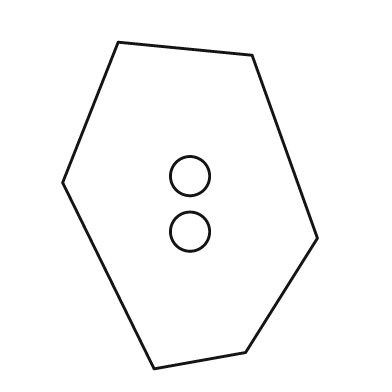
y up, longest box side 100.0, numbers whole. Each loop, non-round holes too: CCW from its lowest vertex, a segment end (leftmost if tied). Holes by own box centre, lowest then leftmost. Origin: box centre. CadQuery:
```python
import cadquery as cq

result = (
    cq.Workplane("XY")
    .moveTo(-11.0, -50.0)
    .lineTo(17.0, -45.0)
    .lineTo(39.0, -10.0)
    .lineTo(19.0, 46.0)
    .lineTo(-22.0, 50.0)
    .lineTo(-39.0, 7.0)
    .close()
    .moveTo(0.0, -8.0)
    .circle(6.0)
    .moveTo(0.0, 9.0)
    .circle(6.0)
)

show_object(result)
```